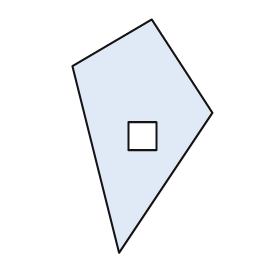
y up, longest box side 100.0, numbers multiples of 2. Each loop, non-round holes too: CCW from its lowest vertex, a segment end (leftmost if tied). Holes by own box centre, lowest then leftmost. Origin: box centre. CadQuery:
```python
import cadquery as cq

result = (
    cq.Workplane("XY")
    .moveTo(-10.0, -50.0)
    .lineTo(30.0, 10.0)
    .lineTo(4.0, 50.0)
    .lineTo(-30.0, 30.0)
    .close()
    .moveTo(-6.0, -6.0)
    .lineTo(6.0, -6.0)
    .lineTo(6.0, 6.0)
    .lineTo(-6.0, 6.0)
    .close()
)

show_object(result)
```